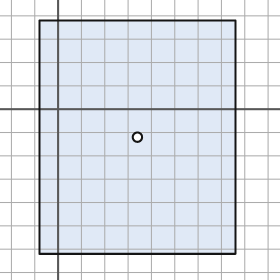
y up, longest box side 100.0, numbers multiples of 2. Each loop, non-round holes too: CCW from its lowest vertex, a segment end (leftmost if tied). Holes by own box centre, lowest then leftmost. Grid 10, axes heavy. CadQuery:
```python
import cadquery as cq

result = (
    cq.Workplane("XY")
    .moveTo(-8.0, -62.0)
    .lineTo(76.0, -62.0)
    .lineTo(76.0, 38.0)
    .lineTo(-8.0, 38.0)
    .close()
    .moveTo(34.0, -12.0)
    .circle(2.0)
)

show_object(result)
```